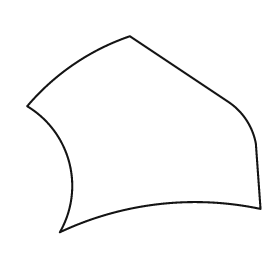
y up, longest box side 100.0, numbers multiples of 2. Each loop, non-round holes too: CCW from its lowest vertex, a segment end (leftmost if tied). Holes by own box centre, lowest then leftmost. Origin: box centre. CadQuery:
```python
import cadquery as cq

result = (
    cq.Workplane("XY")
    .moveTo(-36.0, -42.0)
    .threePointArc((6.0, -30.0), (50.0, -32.0))
    .lineTo(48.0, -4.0)
    .threePointArc((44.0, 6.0), (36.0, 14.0))
    .lineTo(-6.0, 42.0)
    .threePointArc((-30.0, 30.0), (-50.0, 12.0))
    .threePointArc((-32.0, -12.0), (-36.0, -42.0))
    .close()
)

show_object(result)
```